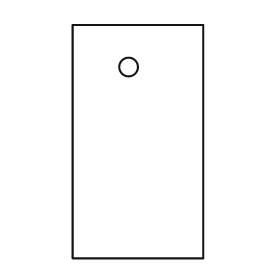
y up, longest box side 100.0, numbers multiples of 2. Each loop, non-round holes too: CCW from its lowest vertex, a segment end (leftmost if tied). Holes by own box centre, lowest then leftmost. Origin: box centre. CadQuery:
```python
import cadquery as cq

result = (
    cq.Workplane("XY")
    .moveTo(-28.0, -50.0)
    .lineTo(28.0, -50.0)
    .lineTo(28.0, 50.0)
    .lineTo(-28.0, 50.0)
    .close()
    .moveTo(-4.0, 32.0)
    .circle(4.0)
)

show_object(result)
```